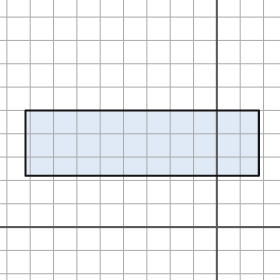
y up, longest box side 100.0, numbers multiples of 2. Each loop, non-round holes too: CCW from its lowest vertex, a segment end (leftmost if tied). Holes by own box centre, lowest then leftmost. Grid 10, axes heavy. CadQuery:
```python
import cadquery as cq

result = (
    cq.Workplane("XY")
    .moveTo(-82.0, 22.0)
    .lineTo(18.0, 22.0)
    .lineTo(18.0, 50.0)
    .lineTo(-82.0, 50.0)
    .close()
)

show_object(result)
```